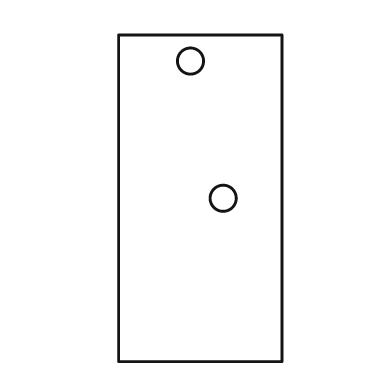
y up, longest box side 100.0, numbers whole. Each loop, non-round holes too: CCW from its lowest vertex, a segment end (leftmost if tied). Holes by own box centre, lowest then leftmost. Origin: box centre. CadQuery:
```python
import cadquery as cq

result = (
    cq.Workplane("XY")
    .moveTo(-25.0, -50.0)
    .lineTo(25.0, -50.0)
    .lineTo(25.0, 50.0)
    .lineTo(-25.0, 50.0)
    .close()
    .moveTo(7.0, 0.0)
    .circle(4.0)
    .moveTo(-3.0, 42.0)
    .circle(4.0)
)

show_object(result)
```